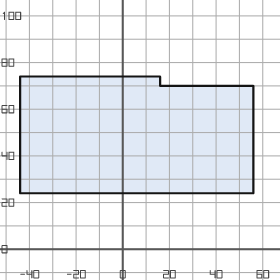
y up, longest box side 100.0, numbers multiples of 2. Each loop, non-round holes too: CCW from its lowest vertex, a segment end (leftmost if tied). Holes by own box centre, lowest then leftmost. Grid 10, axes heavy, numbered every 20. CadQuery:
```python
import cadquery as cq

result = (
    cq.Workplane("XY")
    .moveTo(-44.0, 24.0)
    .lineTo(56.0, 24.0)
    .lineTo(56.0, 70.0)
    .lineTo(16.0, 70.0)
    .lineTo(16.0, 74.0)
    .lineTo(-44.0, 74.0)
    .close()
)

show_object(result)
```